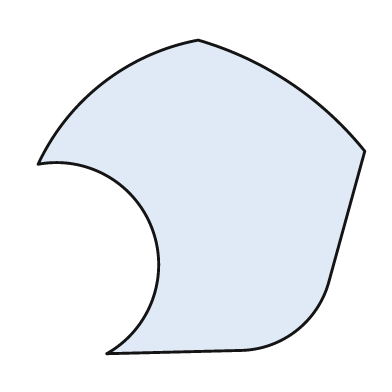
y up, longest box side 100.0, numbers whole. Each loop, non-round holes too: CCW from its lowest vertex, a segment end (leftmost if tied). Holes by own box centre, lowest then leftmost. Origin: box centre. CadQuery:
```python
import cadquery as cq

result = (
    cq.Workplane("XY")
    .moveTo(-29.0, -48.0)
    .lineTo(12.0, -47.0)
    .threePointArc((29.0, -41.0), (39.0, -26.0))
    .lineTo(50.0, 14.0)
    .threePointArc((27.0, 35.0), (-1.0, 48.0))
    .threePointArc((-30.0, 35.0), (-50.0, 10.0))
    .threePointArc((-15.0, -10.0), (-29.0, -48.0))
    .close()
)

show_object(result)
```